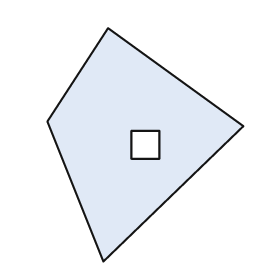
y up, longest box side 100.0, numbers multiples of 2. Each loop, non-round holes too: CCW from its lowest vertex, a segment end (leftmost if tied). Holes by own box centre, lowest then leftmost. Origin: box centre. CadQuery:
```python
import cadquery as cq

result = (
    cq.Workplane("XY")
    .moveTo(-18.0, -50.0)
    .lineTo(42.0, 8.0)
    .lineTo(-16.0, 50.0)
    .lineTo(-42.0, 10.0)
    .close()
    .moveTo(-6.0, -6.0)
    .lineTo(6.0, -6.0)
    .lineTo(6.0, 6.0)
    .lineTo(-6.0, 6.0)
    .close()
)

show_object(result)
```